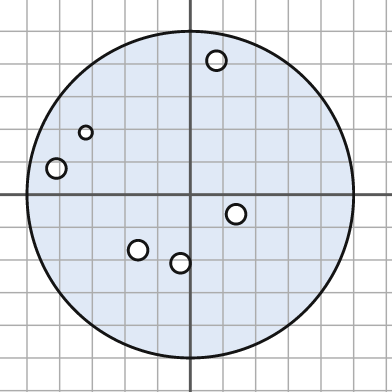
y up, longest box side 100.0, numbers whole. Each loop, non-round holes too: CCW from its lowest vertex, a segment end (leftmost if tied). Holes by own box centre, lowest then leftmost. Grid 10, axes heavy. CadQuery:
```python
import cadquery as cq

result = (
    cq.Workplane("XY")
    .moveTo(0.0, 0.0)
    .circle(50.0)
    .moveTo(-3.0, -21.0)
    .circle(3.0)
    .moveTo(-16.0, -17.0)
    .circle(3.0)
    .moveTo(14.0, -6.0)
    .circle(3.0)
    .moveTo(-41.0, 8.0)
    .circle(3.0)
    .moveTo(-32.0, 19.0)
    .circle(2.0)
    .moveTo(8.0, 41.0)
    .circle(3.0)
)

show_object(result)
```